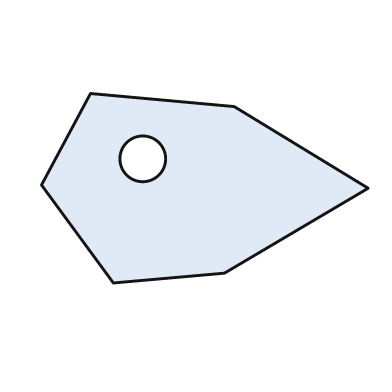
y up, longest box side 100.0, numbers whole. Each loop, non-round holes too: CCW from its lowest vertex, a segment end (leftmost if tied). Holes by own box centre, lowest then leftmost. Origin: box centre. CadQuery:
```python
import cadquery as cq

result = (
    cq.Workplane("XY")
    .moveTo(-28.0, -29.0)
    .lineTo(6.0, -26.0)
    .lineTo(50.0, 0.0)
    .lineTo(9.0, 25.0)
    .lineTo(-35.0, 29.0)
    .lineTo(-50.0, 1.0)
    .close()
    .moveTo(-19.0, 9.0)
    .circle(7.0)
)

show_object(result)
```